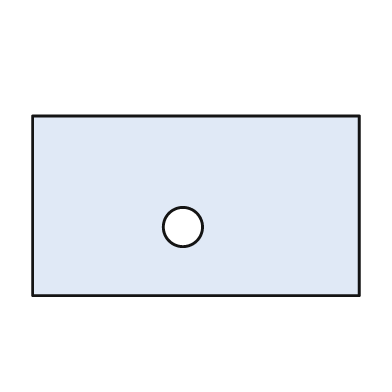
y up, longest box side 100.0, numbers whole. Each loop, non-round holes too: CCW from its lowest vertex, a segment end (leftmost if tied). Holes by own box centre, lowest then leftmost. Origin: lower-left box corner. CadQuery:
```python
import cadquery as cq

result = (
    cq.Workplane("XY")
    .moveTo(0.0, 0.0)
    .lineTo(100.0, 0.0)
    .lineTo(100.0, 55.0)
    .lineTo(0.0, 55.0)
    .close()
    .moveTo(46.0, 21.0)
    .circle(6.0)
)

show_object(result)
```